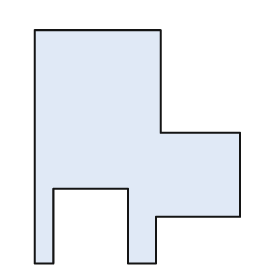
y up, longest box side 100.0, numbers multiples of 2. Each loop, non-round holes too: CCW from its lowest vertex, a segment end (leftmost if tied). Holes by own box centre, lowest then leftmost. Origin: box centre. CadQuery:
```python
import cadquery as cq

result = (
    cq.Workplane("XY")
    .moveTo(-44.0, -50.0)
    .lineTo(-36.0, -50.0)
    .lineTo(-36.0, -18.0)
    .lineTo(-4.0, -18.0)
    .lineTo(-4.0, -50.0)
    .lineTo(8.0, -50.0)
    .lineTo(8.0, -30.0)
    .lineTo(44.0, -30.0)
    .lineTo(44.0, 6.0)
    .lineTo(10.0, 6.0)
    .lineTo(10.0, 50.0)
    .lineTo(-44.0, 50.0)
    .close()
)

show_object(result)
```